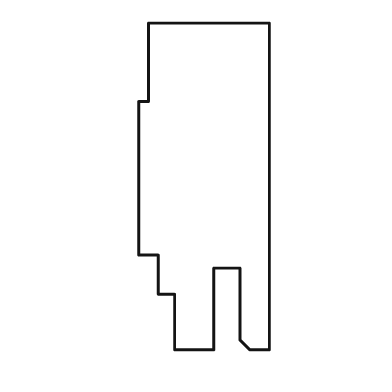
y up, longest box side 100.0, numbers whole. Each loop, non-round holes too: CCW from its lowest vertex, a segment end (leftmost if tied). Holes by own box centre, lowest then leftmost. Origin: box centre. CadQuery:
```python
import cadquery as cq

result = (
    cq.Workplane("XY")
    .moveTo(-9.0, -50.0)
    .lineTo(3.0, -50.0)
    .lineTo(3.0, -25.0)
    .lineTo(11.0, -25.0)
    .lineTo(11.0, -47.0)
    .lineTo(14.0, -50.0)
    .lineTo(20.0, -50.0)
    .lineTo(20.0, 50.0)
    .lineTo(-17.0, 50.0)
    .lineTo(-17.0, 26.0)
    .lineTo(-20.0, 26.0)
    .lineTo(-20.0, -21.0)
    .lineTo(-14.0, -21.0)
    .lineTo(-14.0, -33.0)
    .lineTo(-9.0, -33.0)
    .close()
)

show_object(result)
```